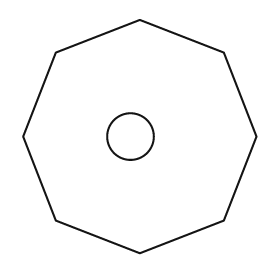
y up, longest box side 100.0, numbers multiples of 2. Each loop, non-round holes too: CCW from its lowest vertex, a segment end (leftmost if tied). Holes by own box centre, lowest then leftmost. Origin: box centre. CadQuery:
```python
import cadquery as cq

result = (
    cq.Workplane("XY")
    .moveTo(0.0, -50.0)
    .lineTo(36.0, -36.0)
    .lineTo(50.0, 0.0)
    .lineTo(36.0, 36.0)
    .lineTo(0.0, 50.0)
    .lineTo(-36.0, 36.0)
    .lineTo(-50.0, 0.0)
    .lineTo(-36.0, -36.0)
    .close()
    .moveTo(-4.0, 0.0)
    .circle(10.0)
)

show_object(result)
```